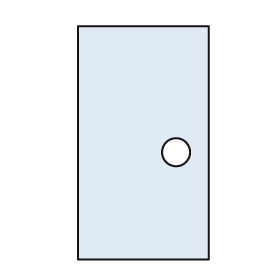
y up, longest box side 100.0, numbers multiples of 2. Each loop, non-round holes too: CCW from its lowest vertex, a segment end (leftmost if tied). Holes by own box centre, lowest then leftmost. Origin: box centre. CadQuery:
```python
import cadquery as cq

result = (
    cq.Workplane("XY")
    .moveTo(-28.0, -50.0)
    .lineTo(28.0, -50.0)
    .lineTo(28.0, 50.0)
    .lineTo(-28.0, 50.0)
    .close()
    .moveTo(14.0, -4.0)
    .circle(6.0)
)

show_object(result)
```